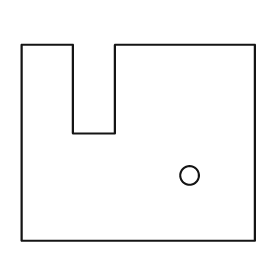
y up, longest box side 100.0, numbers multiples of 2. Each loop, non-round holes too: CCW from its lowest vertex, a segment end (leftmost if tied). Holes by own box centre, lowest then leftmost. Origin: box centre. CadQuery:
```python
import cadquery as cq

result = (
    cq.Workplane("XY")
    .moveTo(-50.0, -42.0)
    .lineTo(50.0, -42.0)
    .lineTo(50.0, 42.0)
    .lineTo(-10.0, 42.0)
    .lineTo(-10.0, 4.0)
    .lineTo(-28.0, 4.0)
    .lineTo(-28.0, 42.0)
    .lineTo(-50.0, 42.0)
    .close()
    .moveTo(22.0, -14.0)
    .circle(4.0)
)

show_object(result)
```